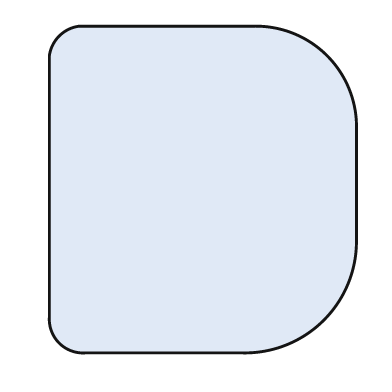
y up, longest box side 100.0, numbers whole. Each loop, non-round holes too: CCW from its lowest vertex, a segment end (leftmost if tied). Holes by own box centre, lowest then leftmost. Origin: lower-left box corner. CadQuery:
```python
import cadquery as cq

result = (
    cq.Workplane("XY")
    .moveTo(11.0, 0.0)
    .lineTo(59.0, 0.0)
    .threePointArc((84.0, 10.0), (94.0, 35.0))
    .lineTo(94.0, 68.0)
    .threePointArc((85.0, 91.0), (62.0, 100.0))
    .lineTo(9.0, 100.0)
    .threePointArc((3.0, 97.0), (0.0, 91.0))
    .lineTo(0.0, 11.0)
    .threePointArc((3.0, 3.0), (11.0, 0.0))
    .close()
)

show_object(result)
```